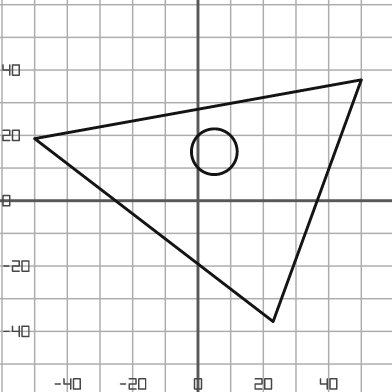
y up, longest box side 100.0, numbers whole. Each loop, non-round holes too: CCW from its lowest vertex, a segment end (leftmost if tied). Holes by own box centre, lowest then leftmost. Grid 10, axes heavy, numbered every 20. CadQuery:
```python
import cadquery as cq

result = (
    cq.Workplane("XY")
    .moveTo(23.0, -37.0)
    .lineTo(50.0, 37.0)
    .lineTo(-50.0, 19.0)
    .close()
    .moveTo(5.0, 15.0)
    .circle(7.0)
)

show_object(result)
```